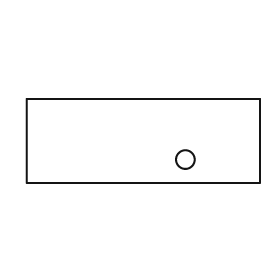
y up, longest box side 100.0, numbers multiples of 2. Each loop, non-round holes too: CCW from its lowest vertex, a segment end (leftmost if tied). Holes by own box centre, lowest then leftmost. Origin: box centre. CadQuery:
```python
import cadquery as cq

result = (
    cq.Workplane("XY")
    .moveTo(-50.0, -18.0)
    .lineTo(50.0, -18.0)
    .lineTo(50.0, 18.0)
    .lineTo(-50.0, 18.0)
    .close()
    .moveTo(18.0, -8.0)
    .circle(4.0)
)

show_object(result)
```